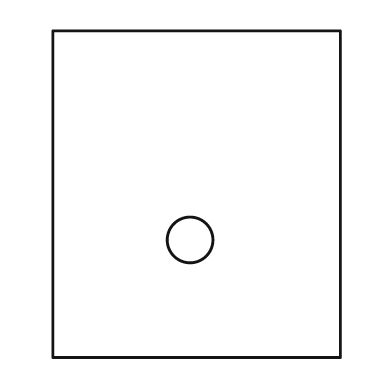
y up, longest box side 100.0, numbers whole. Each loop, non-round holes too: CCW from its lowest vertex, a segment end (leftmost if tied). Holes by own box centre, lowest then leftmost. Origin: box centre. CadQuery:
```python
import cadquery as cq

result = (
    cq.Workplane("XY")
    .moveTo(-44.0, -50.0)
    .lineTo(44.0, -50.0)
    .lineTo(44.0, 50.0)
    .lineTo(-44.0, 50.0)
    .close()
    .moveTo(-2.0, -14.0)
    .circle(7.0)
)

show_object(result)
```